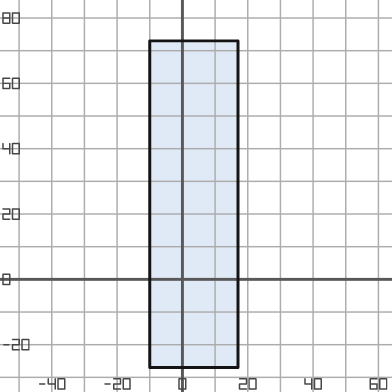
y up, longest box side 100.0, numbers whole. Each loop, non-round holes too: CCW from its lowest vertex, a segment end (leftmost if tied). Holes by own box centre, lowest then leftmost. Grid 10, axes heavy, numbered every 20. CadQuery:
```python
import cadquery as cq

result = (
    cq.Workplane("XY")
    .moveTo(-10.0, -27.0)
    .lineTo(17.0, -27.0)
    .lineTo(17.0, 73.0)
    .lineTo(-10.0, 73.0)
    .close()
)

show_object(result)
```